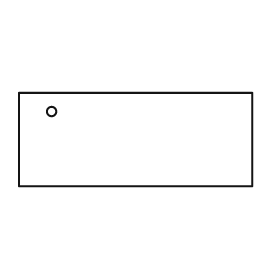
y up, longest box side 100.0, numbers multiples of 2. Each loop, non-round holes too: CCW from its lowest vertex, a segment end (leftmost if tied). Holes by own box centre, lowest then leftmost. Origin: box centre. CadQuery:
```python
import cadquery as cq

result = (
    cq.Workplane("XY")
    .moveTo(-50.0, -20.0)
    .lineTo(50.0, -20.0)
    .lineTo(50.0, 20.0)
    .lineTo(-50.0, 20.0)
    .close()
    .moveTo(-36.0, 12.0)
    .circle(2.0)
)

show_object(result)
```